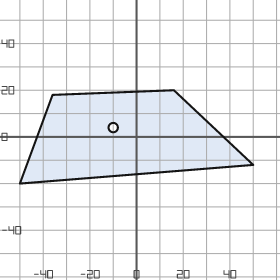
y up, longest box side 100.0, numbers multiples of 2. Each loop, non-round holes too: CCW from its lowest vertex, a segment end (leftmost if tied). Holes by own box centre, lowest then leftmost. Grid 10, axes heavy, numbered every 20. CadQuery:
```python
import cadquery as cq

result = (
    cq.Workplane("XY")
    .moveTo(-50.0, -20.0)
    .lineTo(50.0, -12.0)
    .lineTo(16.0, 20.0)
    .lineTo(-36.0, 18.0)
    .close()
    .moveTo(-10.0, 4.0)
    .circle(2.0)
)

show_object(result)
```